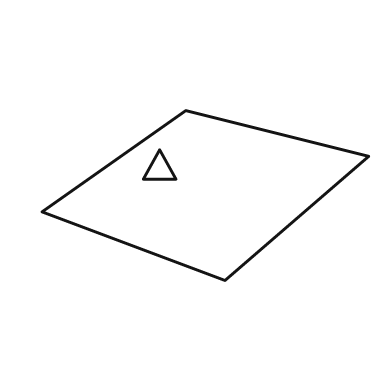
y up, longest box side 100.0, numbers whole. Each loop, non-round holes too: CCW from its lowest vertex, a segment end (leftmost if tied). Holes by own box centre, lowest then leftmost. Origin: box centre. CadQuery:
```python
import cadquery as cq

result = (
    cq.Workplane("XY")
    .moveTo(6.0, -26.0)
    .lineTo(50.0, 12.0)
    .lineTo(-6.0, 26.0)
    .lineTo(-50.0, -5.0)
    .close()
    .moveTo(-19.0, 5.0)
    .lineTo(-9.0, 5.0)
    .lineTo(-14.0, 14.0)
    .close()
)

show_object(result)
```